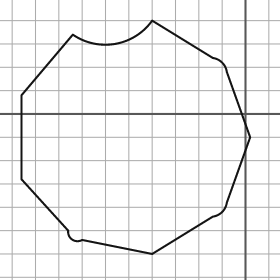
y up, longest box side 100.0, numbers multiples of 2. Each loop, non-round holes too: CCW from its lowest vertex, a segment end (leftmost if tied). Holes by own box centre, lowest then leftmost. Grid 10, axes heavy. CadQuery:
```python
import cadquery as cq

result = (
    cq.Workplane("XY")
    .moveTo(-40.0, -60.0)
    .lineTo(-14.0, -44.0)
    .threePointArc((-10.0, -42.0), (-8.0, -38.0))
    .lineTo(2.0, -10.0)
    .lineTo(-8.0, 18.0)
    .threePointArc((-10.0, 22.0), (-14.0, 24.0))
    .lineTo(-40.0, 40.0)
    .threePointArc((-56.0, 30.0), (-74.0, 34.0))
    .lineTo(-96.0, 8.0)
    .lineTo(-96.0, -28.0)
    .lineTo(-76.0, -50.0)
    .threePointArc((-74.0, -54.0), (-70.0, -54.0))
    .close()
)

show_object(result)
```